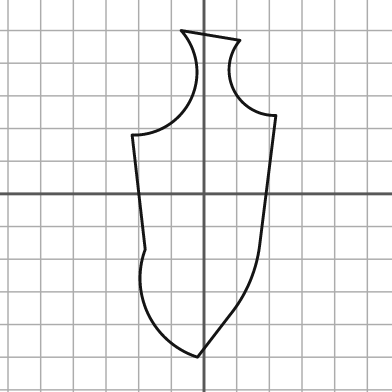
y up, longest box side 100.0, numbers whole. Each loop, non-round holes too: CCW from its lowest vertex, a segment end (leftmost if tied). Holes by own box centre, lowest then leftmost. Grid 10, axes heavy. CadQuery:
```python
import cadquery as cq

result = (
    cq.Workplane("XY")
    .moveTo(-2.0, -50.0)
    .lineTo(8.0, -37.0)
    .threePointArc((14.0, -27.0), (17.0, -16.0))
    .lineTo(22.0, 24.0)
    .threePointArc((9.0, 32.0), (11.0, 47.0))
    .lineTo(-7.0, 50.0)
    .threePointArc((-4.0, 29.0), (-22.0, 18.0))
    .lineTo(-18.0, -17.0)
    .threePointArc((-17.0, -37.0), (-2.0, -50.0))
    .close()
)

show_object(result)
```